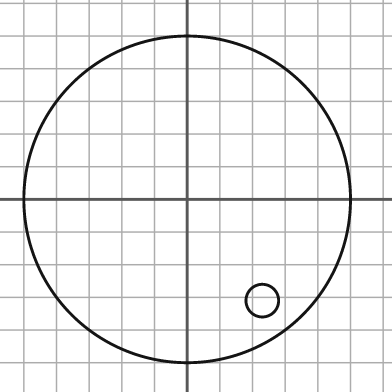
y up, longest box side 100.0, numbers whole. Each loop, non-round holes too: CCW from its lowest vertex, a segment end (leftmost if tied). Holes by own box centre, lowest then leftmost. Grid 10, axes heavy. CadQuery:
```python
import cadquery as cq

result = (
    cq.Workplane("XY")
    .moveTo(0.0, 0.0)
    .circle(50.0)
    .moveTo(23.0, -31.0)
    .circle(5.0)
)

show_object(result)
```